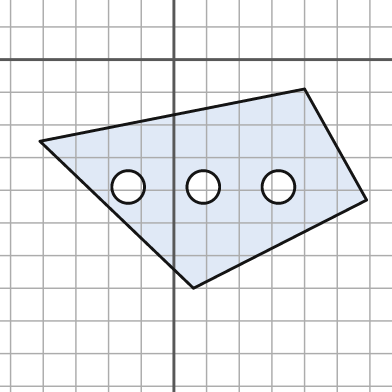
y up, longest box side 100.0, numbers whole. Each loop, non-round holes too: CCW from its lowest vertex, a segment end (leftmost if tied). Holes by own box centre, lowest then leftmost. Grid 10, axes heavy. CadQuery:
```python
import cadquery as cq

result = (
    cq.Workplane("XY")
    .moveTo(6.0, -70.0)
    .lineTo(59.0, -43.0)
    .lineTo(40.0, -9.0)
    .lineTo(-41.0, -25.0)
    .close()
    .moveTo(-14.0, -39.0)
    .circle(5.0)
    .moveTo(9.0, -39.0)
    .circle(5.0)
    .moveTo(32.0, -39.0)
    .circle(5.0)
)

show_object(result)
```